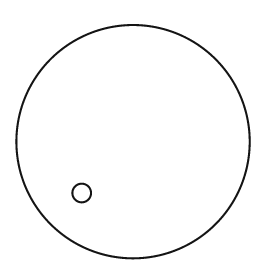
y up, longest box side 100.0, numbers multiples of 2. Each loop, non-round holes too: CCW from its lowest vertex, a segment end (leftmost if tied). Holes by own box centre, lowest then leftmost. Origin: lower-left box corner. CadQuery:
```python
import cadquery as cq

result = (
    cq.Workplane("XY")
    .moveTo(50.0, 50.0)
    .circle(50.0)
    .moveTo(28.0, 28.0)
    .circle(4.0)
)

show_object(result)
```